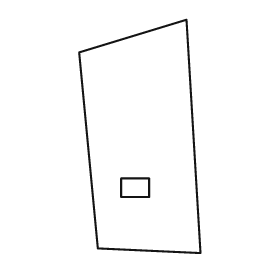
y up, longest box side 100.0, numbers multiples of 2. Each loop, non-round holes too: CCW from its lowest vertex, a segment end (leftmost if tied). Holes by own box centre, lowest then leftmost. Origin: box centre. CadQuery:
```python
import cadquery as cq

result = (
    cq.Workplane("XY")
    .moveTo(26.0, -50.0)
    .lineTo(20.0, 50.0)
    .lineTo(-26.0, 36.0)
    .lineTo(-18.0, -48.0)
    .close()
    .moveTo(-8.0, -26.0)
    .lineTo(4.0, -26.0)
    .lineTo(4.0, -18.0)
    .lineTo(-8.0, -18.0)
    .close()
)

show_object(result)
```